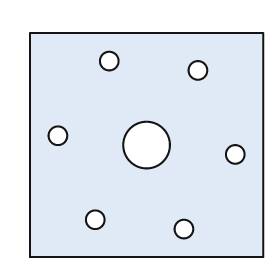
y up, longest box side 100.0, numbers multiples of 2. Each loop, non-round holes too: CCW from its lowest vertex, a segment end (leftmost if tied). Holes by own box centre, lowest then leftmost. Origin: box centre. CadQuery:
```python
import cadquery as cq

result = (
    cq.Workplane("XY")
    .moveTo(-50.0, -48.0)
    .lineTo(50.0, -48.0)
    .lineTo(50.0, 48.0)
    .lineTo(-50.0, 48.0)
    .close()
    .moveTo(16.0, -36.0)
    .circle(4.0)
    .moveTo(-22.0, -32.0)
    .circle(4.0)
    .moveTo(38.0, -4.0)
    .circle(4.0)
    .moveTo(0.0, 0.0)
    .circle(10.0)
    .moveTo(-38.0, 4.0)
    .circle(4.0)
    .moveTo(22.0, 32.0)
    .circle(4.0)
    .moveTo(-16.0, 36.0)
    .circle(4.0)
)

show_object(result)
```